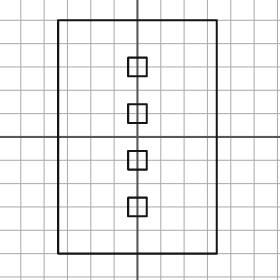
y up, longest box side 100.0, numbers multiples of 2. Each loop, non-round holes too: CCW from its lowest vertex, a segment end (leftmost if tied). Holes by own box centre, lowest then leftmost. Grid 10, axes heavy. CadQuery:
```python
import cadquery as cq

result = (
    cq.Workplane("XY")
    .moveTo(-34.0, -50.0)
    .lineTo(34.0, -50.0)
    .lineTo(34.0, 50.0)
    .lineTo(-34.0, 50.0)
    .close()
    .moveTo(-4.0, -34.0)
    .lineTo(4.0, -34.0)
    .lineTo(4.0, -26.0)
    .lineTo(-4.0, -26.0)
    .close()
    .moveTo(-4.0, -14.0)
    .lineTo(4.0, -14.0)
    .lineTo(4.0, -6.0)
    .lineTo(-4.0, -6.0)
    .close()
    .moveTo(-4.0, 6.0)
    .lineTo(4.0, 6.0)
    .lineTo(4.0, 14.0)
    .lineTo(-4.0, 14.0)
    .close()
    .moveTo(-4.0, 26.0)
    .lineTo(4.0, 26.0)
    .lineTo(4.0, 34.0)
    .lineTo(-4.0, 34.0)
    .close()
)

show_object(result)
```